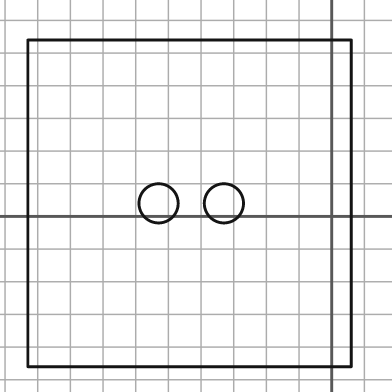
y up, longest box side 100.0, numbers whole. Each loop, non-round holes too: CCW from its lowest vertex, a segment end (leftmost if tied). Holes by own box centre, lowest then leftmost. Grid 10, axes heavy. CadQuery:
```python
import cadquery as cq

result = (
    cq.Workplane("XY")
    .moveTo(-93.0, -46.0)
    .lineTo(6.0, -46.0)
    .lineTo(6.0, 54.0)
    .lineTo(-93.0, 54.0)
    .close()
    .moveTo(-53.0, 4.0)
    .circle(6.0)
    .moveTo(-33.0, 4.0)
    .circle(6.0)
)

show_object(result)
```